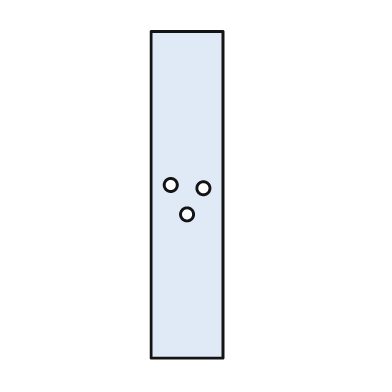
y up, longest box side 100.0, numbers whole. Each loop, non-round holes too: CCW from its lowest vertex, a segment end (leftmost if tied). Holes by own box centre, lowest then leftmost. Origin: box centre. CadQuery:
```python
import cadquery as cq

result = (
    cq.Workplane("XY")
    .moveTo(-11.0, -50.0)
    .lineTo(11.0, -50.0)
    .lineTo(11.0, 50.0)
    .lineTo(-11.0, 50.0)
    .close()
    .moveTo(0.0, -6.0)
    .circle(2.0)
    .moveTo(5.0, 2.0)
    .circle(2.0)
    .moveTo(-5.0, 3.0)
    .circle(2.0)
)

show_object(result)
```